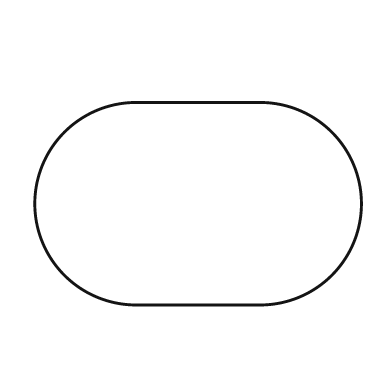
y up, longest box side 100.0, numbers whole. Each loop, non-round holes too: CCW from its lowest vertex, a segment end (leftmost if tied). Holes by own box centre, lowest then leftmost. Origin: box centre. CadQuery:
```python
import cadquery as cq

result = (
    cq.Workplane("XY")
    .moveTo(-19.0, -31.0)
    .lineTo(19.0, -31.0)
    .threePointArc((50.0, 0.0), (19.0, 31.0))
    .lineTo(-19.0, 31.0)
    .threePointArc((-50.0, 0.0), (-19.0, -31.0))
    .close()
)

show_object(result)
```